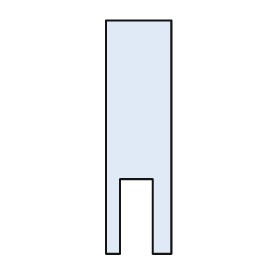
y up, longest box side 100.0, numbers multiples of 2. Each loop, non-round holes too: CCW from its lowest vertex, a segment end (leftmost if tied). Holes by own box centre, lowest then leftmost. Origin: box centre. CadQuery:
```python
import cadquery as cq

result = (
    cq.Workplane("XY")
    .moveTo(-14.0, -50.0)
    .lineTo(-8.0, -50.0)
    .lineTo(-8.0, -18.0)
    .lineTo(6.0, -18.0)
    .lineTo(6.0, -50.0)
    .lineTo(14.0, -50.0)
    .lineTo(14.0, 50.0)
    .lineTo(-14.0, 50.0)
    .close()
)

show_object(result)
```